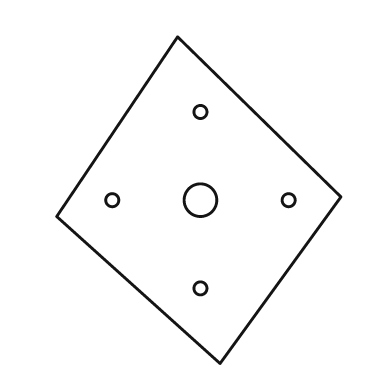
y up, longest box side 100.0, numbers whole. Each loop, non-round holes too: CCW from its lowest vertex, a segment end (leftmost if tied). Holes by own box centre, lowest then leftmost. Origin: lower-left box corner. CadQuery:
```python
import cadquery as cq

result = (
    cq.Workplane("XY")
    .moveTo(50.0, 0.0)
    .lineTo(87.0, 51.0)
    .lineTo(37.0, 100.0)
    .lineTo(0.0, 45.0)
    .close()
    .moveTo(44.0, 23.0)
    .circle(2.0)
    .moveTo(17.0, 50.0)
    .circle(2.0)
    .moveTo(44.0, 50.0)
    .circle(5.0)
    .moveTo(71.0, 50.0)
    .circle(2.0)
    .moveTo(44.0, 77.0)
    .circle(2.0)
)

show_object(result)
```